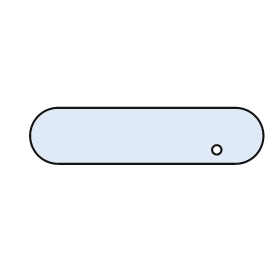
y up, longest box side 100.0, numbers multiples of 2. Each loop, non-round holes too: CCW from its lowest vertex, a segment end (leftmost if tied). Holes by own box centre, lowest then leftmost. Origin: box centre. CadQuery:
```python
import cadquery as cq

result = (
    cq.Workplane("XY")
    .moveTo(-38.0, -12.0)
    .lineTo(38.0, -12.0)
    .threePointArc((50.0, 0.0), (38.0, 12.0))
    .lineTo(-38.0, 12.0)
    .threePointArc((-50.0, 0.0), (-38.0, -12.0))
    .close()
    .moveTo(30.0, -6.0)
    .circle(2.0)
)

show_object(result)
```